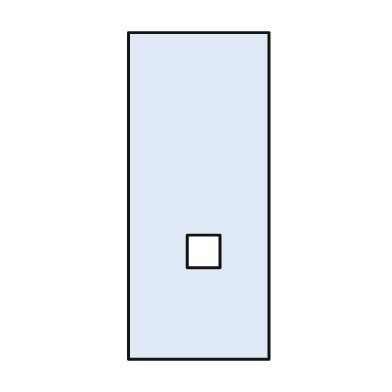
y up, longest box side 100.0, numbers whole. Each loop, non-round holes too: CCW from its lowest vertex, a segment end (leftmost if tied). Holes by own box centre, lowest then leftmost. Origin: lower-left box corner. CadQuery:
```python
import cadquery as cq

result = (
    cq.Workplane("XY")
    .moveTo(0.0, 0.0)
    .lineTo(43.0, 0.0)
    .lineTo(43.0, 100.0)
    .lineTo(0.0, 100.0)
    .close()
    .moveTo(18.0, 28.0)
    .lineTo(28.0, 28.0)
    .lineTo(28.0, 38.0)
    .lineTo(18.0, 38.0)
    .close()
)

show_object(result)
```